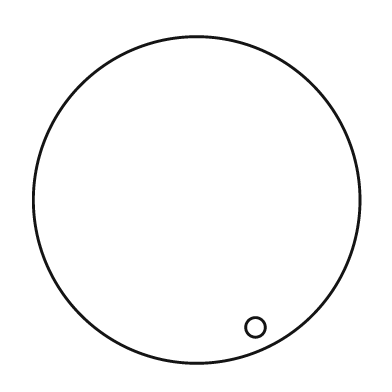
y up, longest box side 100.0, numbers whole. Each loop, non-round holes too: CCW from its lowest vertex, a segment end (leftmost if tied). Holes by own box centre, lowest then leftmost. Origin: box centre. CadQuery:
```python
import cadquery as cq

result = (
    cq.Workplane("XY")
    .moveTo(0.0, 0.0)
    .circle(50.0)
    .moveTo(18.0, -39.0)
    .circle(3.0)
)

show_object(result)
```